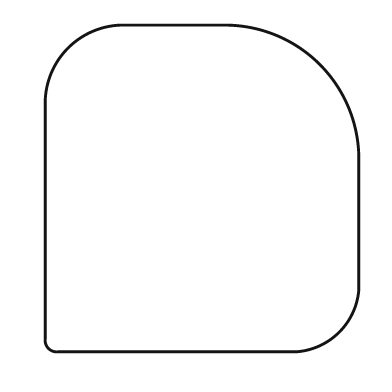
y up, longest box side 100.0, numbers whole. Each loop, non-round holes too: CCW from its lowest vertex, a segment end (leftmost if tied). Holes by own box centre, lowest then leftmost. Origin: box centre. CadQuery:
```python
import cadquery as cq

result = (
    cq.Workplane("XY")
    .moveTo(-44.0, -50.0)
    .lineTo(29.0, -50.0)
    .threePointArc((42.0, -44.0), (48.0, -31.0))
    .lineTo(48.0, 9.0)
    .threePointArc((36.0, 38.0), (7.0, 50.0))
    .lineTo(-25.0, 50.0)
    .threePointArc((-41.0, 43.0), (-48.0, 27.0))
    .lineTo(-48.0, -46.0)
    .threePointArc((-47.0, -49.0), (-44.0, -50.0))
    .close()
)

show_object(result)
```